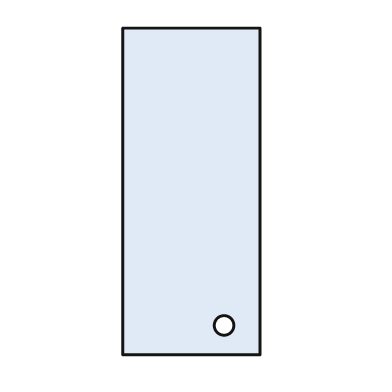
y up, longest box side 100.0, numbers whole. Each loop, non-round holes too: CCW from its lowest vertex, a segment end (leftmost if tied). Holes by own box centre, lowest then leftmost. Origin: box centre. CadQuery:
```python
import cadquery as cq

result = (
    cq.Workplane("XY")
    .moveTo(-21.0, -50.0)
    .lineTo(21.0, -50.0)
    .lineTo(21.0, 50.0)
    .lineTo(-21.0, 50.0)
    .close()
    .moveTo(10.0, -41.0)
    .circle(3.0)
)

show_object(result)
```